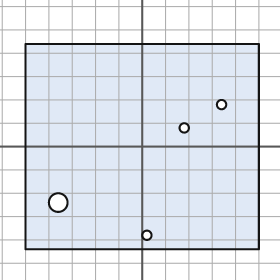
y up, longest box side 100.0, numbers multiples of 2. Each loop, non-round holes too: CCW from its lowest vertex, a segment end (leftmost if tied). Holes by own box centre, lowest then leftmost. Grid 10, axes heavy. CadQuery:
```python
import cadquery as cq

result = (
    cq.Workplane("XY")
    .moveTo(-50.0, -44.0)
    .lineTo(50.0, -44.0)
    .lineTo(50.0, 44.0)
    .lineTo(-50.0, 44.0)
    .close()
    .moveTo(2.0, -38.0)
    .circle(2.0)
    .moveTo(-36.0, -24.0)
    .circle(4.0)
    .moveTo(18.0, 8.0)
    .circle(2.0)
    .moveTo(34.0, 18.0)
    .circle(2.0)
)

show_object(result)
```